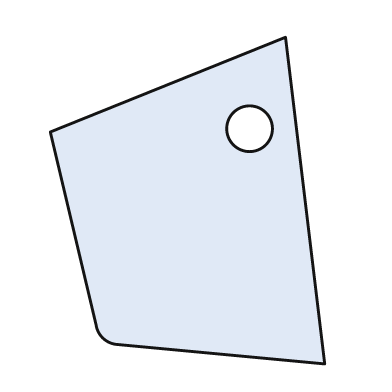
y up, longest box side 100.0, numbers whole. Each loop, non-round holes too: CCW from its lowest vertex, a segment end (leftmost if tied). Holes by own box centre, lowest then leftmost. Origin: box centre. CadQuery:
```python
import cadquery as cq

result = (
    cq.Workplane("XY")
    .moveTo(42.0, -50.0)
    .lineTo(30.0, 50.0)
    .lineTo(-42.0, 21.0)
    .lineTo(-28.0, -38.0)
    .threePointArc((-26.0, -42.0), (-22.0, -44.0))
    .close()
    .moveTo(19.0, 22.0)
    .circle(7.0)
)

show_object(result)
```